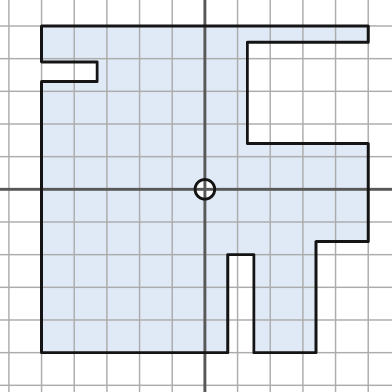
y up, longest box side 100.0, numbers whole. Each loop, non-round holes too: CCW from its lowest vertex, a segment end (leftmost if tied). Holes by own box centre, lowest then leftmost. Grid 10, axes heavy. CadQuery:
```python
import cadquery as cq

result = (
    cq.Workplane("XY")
    .moveTo(-50.0, -50.0)
    .lineTo(7.0, -50.0)
    .lineTo(7.0, -20.0)
    .lineTo(15.0, -20.0)
    .lineTo(15.0, -50.0)
    .lineTo(34.0, -50.0)
    .lineTo(34.0, -16.0)
    .lineTo(50.0, -16.0)
    .lineTo(50.0, 14.0)
    .lineTo(13.0, 14.0)
    .lineTo(13.0, 45.0)
    .lineTo(50.0, 45.0)
    .lineTo(50.0, 50.0)
    .lineTo(-50.0, 50.0)
    .lineTo(-50.0, 39.0)
    .lineTo(-33.0, 39.0)
    .lineTo(-33.0, 33.0)
    .lineTo(-50.0, 33.0)
    .close()
    .moveTo(0.0, 0.0)
    .circle(3.0)
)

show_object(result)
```